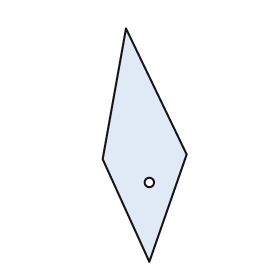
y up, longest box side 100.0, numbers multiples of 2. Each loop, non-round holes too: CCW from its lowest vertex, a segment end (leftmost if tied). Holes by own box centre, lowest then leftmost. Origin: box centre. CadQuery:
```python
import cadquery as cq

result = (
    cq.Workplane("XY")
    .moveTo(2.0, -50.0)
    .lineTo(18.0, -4.0)
    .lineTo(-8.0, 50.0)
    .lineTo(-18.0, -6.0)
    .close()
    .moveTo(2.0, -16.0)
    .circle(2.0)
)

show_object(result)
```